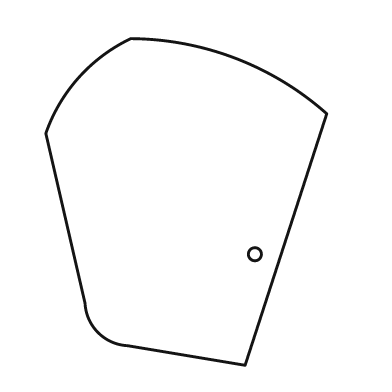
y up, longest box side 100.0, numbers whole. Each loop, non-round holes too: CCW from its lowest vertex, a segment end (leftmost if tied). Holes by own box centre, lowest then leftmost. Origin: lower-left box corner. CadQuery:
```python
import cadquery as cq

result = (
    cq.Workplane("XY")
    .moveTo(61.0, 0.0)
    .lineTo(86.0, 77.0)
    .threePointArc((58.0, 94.0), (26.0, 100.0))
    .threePointArc((10.0, 88.0), (0.0, 71.0))
    .lineTo(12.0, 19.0)
    .threePointArc((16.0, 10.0), (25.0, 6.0))
    .close()
    .moveTo(64.0, 34.0)
    .circle(2.0)
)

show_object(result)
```